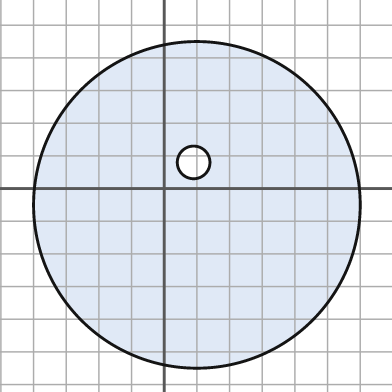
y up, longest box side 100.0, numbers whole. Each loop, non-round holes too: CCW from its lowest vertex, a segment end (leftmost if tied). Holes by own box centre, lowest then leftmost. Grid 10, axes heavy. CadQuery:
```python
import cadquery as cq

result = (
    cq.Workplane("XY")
    .moveTo(10.0, -5.0)
    .circle(50.0)
    .moveTo(9.0, 8.0)
    .circle(5.0)
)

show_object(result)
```